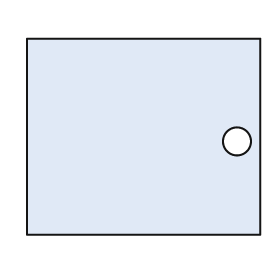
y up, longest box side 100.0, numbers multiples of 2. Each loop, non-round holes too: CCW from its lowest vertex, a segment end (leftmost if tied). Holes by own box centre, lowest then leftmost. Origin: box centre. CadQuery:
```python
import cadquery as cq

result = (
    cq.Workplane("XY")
    .moveTo(-50.0, -42.0)
    .lineTo(50.0, -42.0)
    .lineTo(50.0, 42.0)
    .lineTo(-50.0, 42.0)
    .close()
    .moveTo(40.0, -2.0)
    .circle(6.0)
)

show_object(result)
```